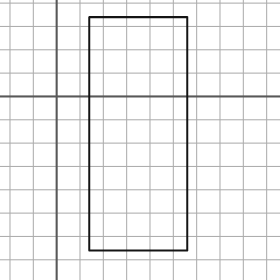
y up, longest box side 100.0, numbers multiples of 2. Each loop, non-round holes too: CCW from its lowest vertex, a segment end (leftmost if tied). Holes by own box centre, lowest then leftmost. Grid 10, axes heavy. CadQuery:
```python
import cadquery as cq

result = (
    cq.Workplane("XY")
    .moveTo(14.0, -66.0)
    .lineTo(56.0, -66.0)
    .lineTo(56.0, 34.0)
    .lineTo(14.0, 34.0)
    .close()
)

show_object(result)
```